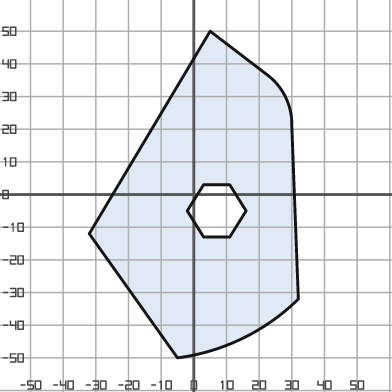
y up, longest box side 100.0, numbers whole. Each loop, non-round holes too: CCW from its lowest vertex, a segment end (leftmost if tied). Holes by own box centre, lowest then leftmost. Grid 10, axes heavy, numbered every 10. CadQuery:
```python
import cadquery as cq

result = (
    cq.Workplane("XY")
    .moveTo(-5.0, -50.0)
    .threePointArc((15.0, -44.0), (32.0, -32.0))
    .lineTo(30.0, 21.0)
    .threePointArc((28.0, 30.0), (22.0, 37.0))
    .lineTo(5.0, 50.0)
    .lineTo(-32.0, -12.0)
    .close()
    .moveTo(3.0, -13.0)
    .lineTo(11.0, -13.0)
    .lineTo(16.0, -5.0)
    .lineTo(11.0, 3.0)
    .lineTo(3.0, 3.0)
    .lineTo(-2.0, -5.0)
    .close()
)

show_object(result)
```